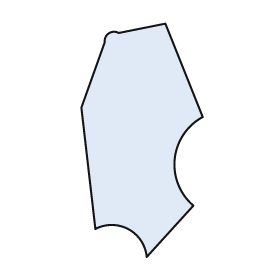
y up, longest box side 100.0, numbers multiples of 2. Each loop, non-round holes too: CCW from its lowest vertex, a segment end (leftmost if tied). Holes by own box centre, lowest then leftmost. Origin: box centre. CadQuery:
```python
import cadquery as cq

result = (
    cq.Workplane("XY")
    .moveTo(2.0, -50.0)
    .lineTo(22.0, -28.0)
    .threePointArc((14.0, -8.0), (26.0, 10.0))
    .lineTo(10.0, 50.0)
    .lineTo(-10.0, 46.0)
    .threePointArc((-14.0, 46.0), (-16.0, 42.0))
    .lineTo(-26.0, 14.0)
    .lineTo(-20.0, -38.0)
    .threePointArc((-6.0, -38.0), (2.0, -50.0))
    .close()
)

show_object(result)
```